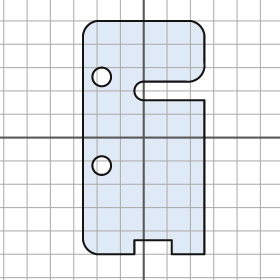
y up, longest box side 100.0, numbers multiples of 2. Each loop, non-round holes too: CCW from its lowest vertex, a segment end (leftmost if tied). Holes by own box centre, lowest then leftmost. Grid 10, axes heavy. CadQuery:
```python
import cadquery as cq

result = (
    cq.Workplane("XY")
    .moveTo(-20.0, -50.0)
    .lineTo(-4.0, -50.0)
    .lineTo(-4.0, -44.0)
    .lineTo(12.0, -44.0)
    .lineTo(12.0, -50.0)
    .lineTo(26.0, -50.0)
    .lineTo(26.0, 16.0)
    .lineTo(0.0, 16.0)
    .threePointArc((-4.0, 20.0), (0.0, 24.0))
    .lineTo(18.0, 24.0)
    .threePointArc((24.0, 26.0), (26.0, 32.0))
    .lineTo(26.0, 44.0)
    .threePointArc((24.0, 48.0), (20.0, 50.0))
    .lineTo(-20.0, 50.0)
    .threePointArc((-24.0, 48.0), (-26.0, 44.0))
    .lineTo(-26.0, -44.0)
    .threePointArc((-24.0, -48.0), (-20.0, -50.0))
    .close()
    .moveTo(-18.0, -12.0)
    .circle(4.0)
    .moveTo(-18.0, 26.0)
    .circle(4.0)
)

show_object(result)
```